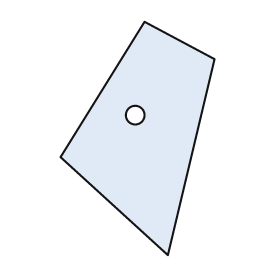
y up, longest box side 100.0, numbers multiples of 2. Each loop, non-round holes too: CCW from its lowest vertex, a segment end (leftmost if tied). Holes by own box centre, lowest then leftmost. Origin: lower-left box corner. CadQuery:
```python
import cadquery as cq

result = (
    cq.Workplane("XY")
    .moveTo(46.0, 0.0)
    .lineTo(66.0, 84.0)
    .lineTo(36.0, 100.0)
    .lineTo(0.0, 42.0)
    .close()
    .moveTo(32.0, 60.0)
    .circle(4.0)
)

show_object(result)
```